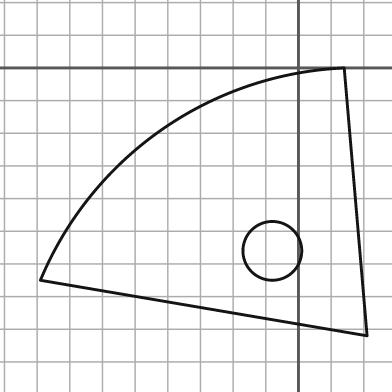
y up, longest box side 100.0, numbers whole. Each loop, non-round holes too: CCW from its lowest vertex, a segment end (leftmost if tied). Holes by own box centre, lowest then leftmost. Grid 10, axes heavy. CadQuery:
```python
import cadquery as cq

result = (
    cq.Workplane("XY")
    .moveTo(21.0, -82.0)
    .lineTo(14.0, 0.0)
    .threePointArc((-42.0, -19.0), (-79.0, -65.0))
    .close()
    .moveTo(-8.0, -56.0)
    .circle(9.0)
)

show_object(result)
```